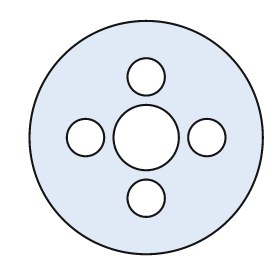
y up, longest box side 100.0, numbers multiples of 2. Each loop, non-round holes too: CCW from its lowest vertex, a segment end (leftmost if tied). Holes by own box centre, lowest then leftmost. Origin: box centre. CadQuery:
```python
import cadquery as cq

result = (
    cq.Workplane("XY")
    .moveTo(0.0, 0.0)
    .circle(50.0)
    .moveTo(0.0, -26.0)
    .circle(8.0)
    .moveTo(-26.0, 0.0)
    .circle(8.0)
    .moveTo(0.0, 0.0)
    .circle(14.0)
    .moveTo(26.0, 0.0)
    .circle(8.0)
    .moveTo(0.0, 26.0)
    .circle(8.0)
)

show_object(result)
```